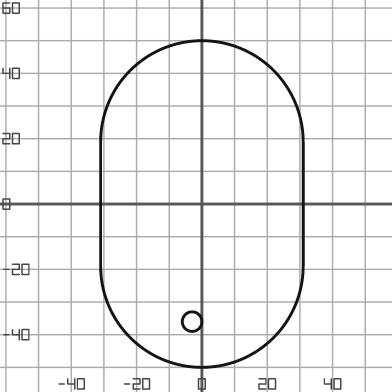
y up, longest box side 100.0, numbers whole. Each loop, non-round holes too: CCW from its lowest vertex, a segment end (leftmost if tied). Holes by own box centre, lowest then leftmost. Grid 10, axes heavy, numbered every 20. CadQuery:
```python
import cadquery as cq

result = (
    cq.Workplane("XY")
    .moveTo(-31.0, -19.0)
    .threePointArc((0.0, -50.0), (31.0, -19.0))
    .lineTo(31.0, 19.0)
    .threePointArc((0.0, 50.0), (-31.0, 19.0))
    .close()
    .moveTo(-3.0, -36.0)
    .circle(3.0)
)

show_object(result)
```